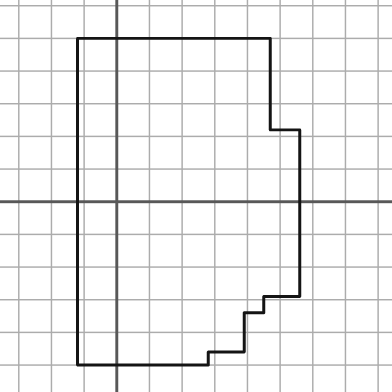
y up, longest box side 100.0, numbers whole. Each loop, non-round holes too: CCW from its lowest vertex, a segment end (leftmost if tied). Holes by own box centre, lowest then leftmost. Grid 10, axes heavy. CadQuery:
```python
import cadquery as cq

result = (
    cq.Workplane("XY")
    .moveTo(-12.0, -50.0)
    .lineTo(28.0, -50.0)
    .lineTo(28.0, -46.0)
    .lineTo(39.0, -46.0)
    .lineTo(39.0, -34.0)
    .lineTo(45.0, -34.0)
    .lineTo(45.0, -29.0)
    .lineTo(56.0, -29.0)
    .lineTo(56.0, 22.0)
    .lineTo(47.0, 22.0)
    .lineTo(47.0, 50.0)
    .lineTo(-12.0, 50.0)
    .close()
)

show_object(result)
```